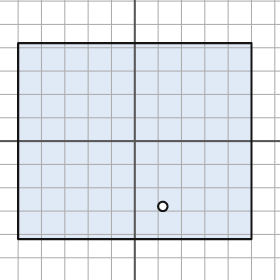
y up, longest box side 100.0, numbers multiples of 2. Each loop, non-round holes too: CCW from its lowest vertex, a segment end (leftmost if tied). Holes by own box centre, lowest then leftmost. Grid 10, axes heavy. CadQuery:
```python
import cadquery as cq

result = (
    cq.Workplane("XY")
    .moveTo(-50.0, -42.0)
    .lineTo(50.0, -42.0)
    .lineTo(50.0, 42.0)
    .lineTo(-50.0, 42.0)
    .close()
    .moveTo(12.0, -28.0)
    .circle(2.0)
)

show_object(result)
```